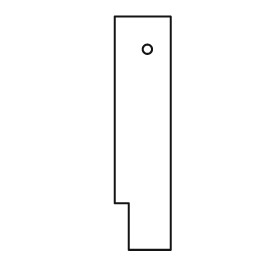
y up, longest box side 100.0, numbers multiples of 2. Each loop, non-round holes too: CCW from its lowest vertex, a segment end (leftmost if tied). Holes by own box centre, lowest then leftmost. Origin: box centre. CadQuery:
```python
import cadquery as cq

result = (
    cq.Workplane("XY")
    .moveTo(-6.0, -50.0)
    .lineTo(12.0, -50.0)
    .lineTo(12.0, 50.0)
    .lineTo(-12.0, 50.0)
    .lineTo(-12.0, -30.0)
    .lineTo(-6.0, -30.0)
    .close()
    .moveTo(2.0, 36.0)
    .circle(2.0)
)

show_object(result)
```